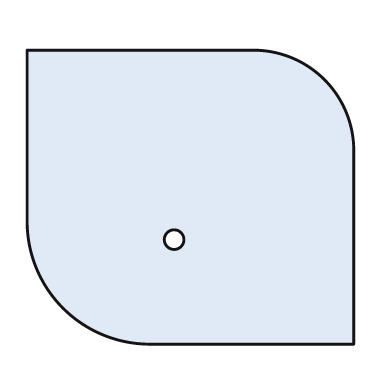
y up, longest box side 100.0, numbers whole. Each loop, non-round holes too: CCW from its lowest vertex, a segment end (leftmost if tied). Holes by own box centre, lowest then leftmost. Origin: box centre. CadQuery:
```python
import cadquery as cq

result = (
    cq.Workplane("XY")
    .moveTo(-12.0, -45.0)
    .lineTo(50.0, -45.0)
    .lineTo(50.0, 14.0)
    .threePointArc((41.0, 36.0), (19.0, 45.0))
    .lineTo(-50.0, 45.0)
    .lineTo(-50.0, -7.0)
    .threePointArc((-39.0, -34.0), (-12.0, -45.0))
    .close()
    .moveTo(-5.0, -13.0)
    .circle(3.0)
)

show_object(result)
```